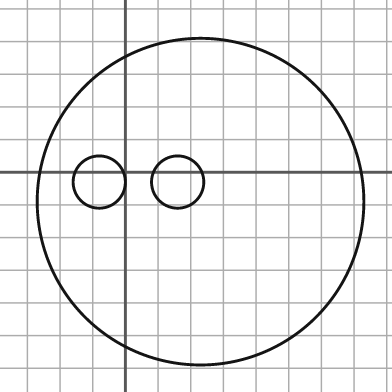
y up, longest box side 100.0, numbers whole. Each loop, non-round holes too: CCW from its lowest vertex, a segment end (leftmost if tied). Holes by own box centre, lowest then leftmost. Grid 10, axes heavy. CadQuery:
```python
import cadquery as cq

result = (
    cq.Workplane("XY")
    .moveTo(23.0, -9.0)
    .circle(50.0)
    .moveTo(-8.0, -3.0)
    .circle(8.0)
    .moveTo(16.0, -3.0)
    .circle(8.0)
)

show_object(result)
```